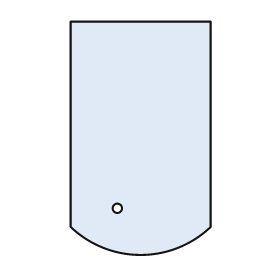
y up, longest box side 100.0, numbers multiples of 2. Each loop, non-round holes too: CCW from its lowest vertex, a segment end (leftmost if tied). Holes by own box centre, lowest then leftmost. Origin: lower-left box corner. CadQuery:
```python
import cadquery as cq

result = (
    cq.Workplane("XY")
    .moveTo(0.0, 12.0)
    .threePointArc((30.0, 0.0), (60.0, 12.0))
    .lineTo(60.0, 100.0)
    .lineTo(0.0, 100.0)
    .close()
    .moveTo(20.0, 20.0)
    .circle(2.0)
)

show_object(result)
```